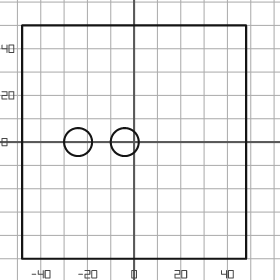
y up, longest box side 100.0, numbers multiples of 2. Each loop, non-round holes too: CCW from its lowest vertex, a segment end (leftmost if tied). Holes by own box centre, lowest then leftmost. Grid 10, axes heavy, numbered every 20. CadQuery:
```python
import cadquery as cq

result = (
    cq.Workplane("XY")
    .moveTo(-48.0, -50.0)
    .lineTo(48.0, -50.0)
    .lineTo(48.0, 50.0)
    .lineTo(-48.0, 50.0)
    .close()
    .moveTo(-24.0, 0.0)
    .circle(6.0)
    .moveTo(-4.0, 0.0)
    .circle(6.0)
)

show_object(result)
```